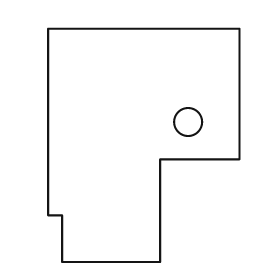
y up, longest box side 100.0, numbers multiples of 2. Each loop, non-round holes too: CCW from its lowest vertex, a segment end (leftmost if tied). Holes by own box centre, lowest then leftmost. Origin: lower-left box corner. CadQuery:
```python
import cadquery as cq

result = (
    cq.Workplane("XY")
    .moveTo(6.0, 0.0)
    .lineTo(48.0, 0.0)
    .lineTo(48.0, 44.0)
    .lineTo(82.0, 44.0)
    .lineTo(82.0, 100.0)
    .lineTo(0.0, 100.0)
    .lineTo(0.0, 20.0)
    .lineTo(6.0, 20.0)
    .close()
    .moveTo(60.0, 60.0)
    .circle(6.0)
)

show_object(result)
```